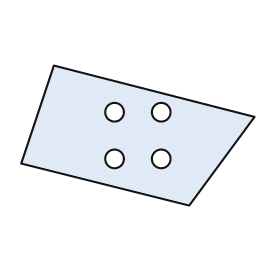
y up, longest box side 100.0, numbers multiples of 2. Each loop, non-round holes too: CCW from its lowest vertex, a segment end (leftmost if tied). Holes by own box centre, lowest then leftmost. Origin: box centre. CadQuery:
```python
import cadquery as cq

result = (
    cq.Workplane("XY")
    .moveTo(22.0, -30.0)
    .lineTo(50.0, 8.0)
    .lineTo(-36.0, 30.0)
    .lineTo(-50.0, -12.0)
    .close()
    .moveTo(-10.0, -10.0)
    .circle(4.0)
    .moveTo(10.0, -10.0)
    .circle(4.0)
    .moveTo(-10.0, 10.0)
    .circle(4.0)
    .moveTo(10.0, 10.0)
    .circle(4.0)
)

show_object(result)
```